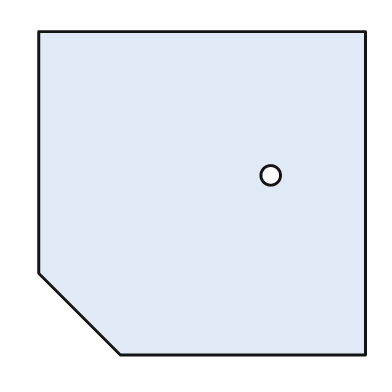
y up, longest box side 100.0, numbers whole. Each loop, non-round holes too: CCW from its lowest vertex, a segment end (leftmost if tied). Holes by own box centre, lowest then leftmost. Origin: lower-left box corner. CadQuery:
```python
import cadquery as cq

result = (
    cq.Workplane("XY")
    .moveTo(25.0, 0.0)
    .lineTo(100.0, 0.0)
    .lineTo(100.0, 99.0)
    .lineTo(0.0, 99.0)
    .lineTo(0.0, 25.0)
    .close()
    .moveTo(71.0, 55.0)
    .circle(3.0)
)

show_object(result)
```